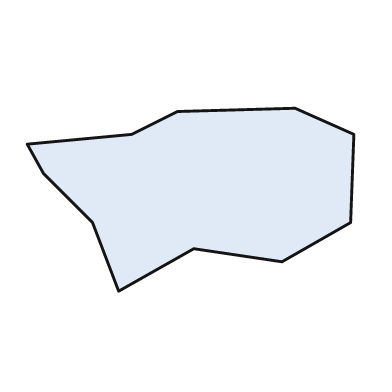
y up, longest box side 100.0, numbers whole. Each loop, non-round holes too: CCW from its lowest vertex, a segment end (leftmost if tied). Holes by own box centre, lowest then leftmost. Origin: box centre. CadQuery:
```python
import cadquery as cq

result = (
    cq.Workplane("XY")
    .moveTo(-22.0, -28.0)
    .lineTo(1.0, -15.0)
    .lineTo(28.0, -19.0)
    .lineTo(49.0, -7.0)
    .lineTo(50.0, 20.0)
    .lineTo(32.0, 28.0)
    .lineTo(-4.0, 27.0)
    .lineTo(-18.0, 20.0)
    .lineTo(-50.0, 17.0)
    .lineTo(-45.0, 8.0)
    .lineTo(-30.0, -7.0)
    .close()
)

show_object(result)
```